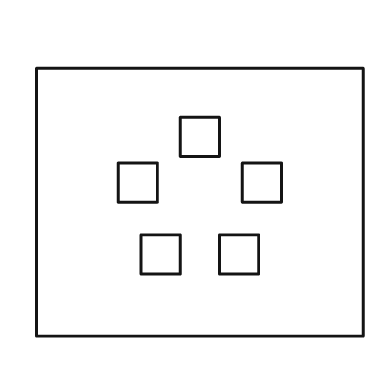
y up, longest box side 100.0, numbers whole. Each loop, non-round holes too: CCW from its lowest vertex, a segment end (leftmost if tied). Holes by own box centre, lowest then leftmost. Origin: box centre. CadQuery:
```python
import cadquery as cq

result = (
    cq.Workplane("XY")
    .moveTo(-50.0, -41.0)
    .lineTo(50.0, -41.0)
    .lineTo(50.0, 41.0)
    .lineTo(-50.0, 41.0)
    .close()
    .moveTo(-18.0, -22.0)
    .lineTo(-6.0, -22.0)
    .lineTo(-6.0, -10.0)
    .lineTo(-18.0, -10.0)
    .close()
    .moveTo(6.0, -22.0)
    .lineTo(18.0, -22.0)
    .lineTo(18.0, -10.0)
    .lineTo(6.0, -10.0)
    .close()
    .moveTo(-25.0, 0.0)
    .lineTo(-13.0, 0.0)
    .lineTo(-13.0, 12.0)
    .lineTo(-25.0, 12.0)
    .close()
    .moveTo(13.0, 0.0)
    .lineTo(25.0, 0.0)
    .lineTo(25.0, 12.0)
    .lineTo(13.0, 12.0)
    .close()
    .moveTo(-6.0, 14.0)
    .lineTo(6.0, 14.0)
    .lineTo(6.0, 26.0)
    .lineTo(-6.0, 26.0)
    .close()
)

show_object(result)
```